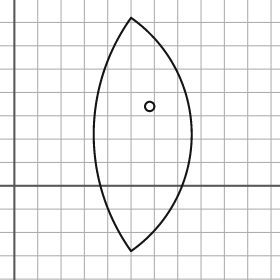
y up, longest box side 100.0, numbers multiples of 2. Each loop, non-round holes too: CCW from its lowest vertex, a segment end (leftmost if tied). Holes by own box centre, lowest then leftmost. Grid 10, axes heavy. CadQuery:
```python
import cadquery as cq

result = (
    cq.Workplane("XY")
    .moveTo(50.0, -28.0)
    .threePointArc((76.0, 22.0), (50.0, 72.0))
    .threePointArc((34.0, 22.0), (50.0, -28.0))
    .close()
    .moveTo(58.0, 34.0)
    .circle(2.0)
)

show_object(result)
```